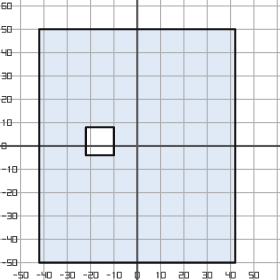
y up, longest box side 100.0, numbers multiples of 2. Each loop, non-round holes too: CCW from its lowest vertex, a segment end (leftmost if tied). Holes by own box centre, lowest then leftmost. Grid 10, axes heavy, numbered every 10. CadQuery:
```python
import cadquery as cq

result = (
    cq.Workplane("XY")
    .moveTo(-42.0, -50.0)
    .lineTo(42.0, -50.0)
    .lineTo(42.0, 50.0)
    .lineTo(-42.0, 50.0)
    .close()
    .moveTo(-22.0, -4.0)
    .lineTo(-10.0, -4.0)
    .lineTo(-10.0, 8.0)
    .lineTo(-22.0, 8.0)
    .close()
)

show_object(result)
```